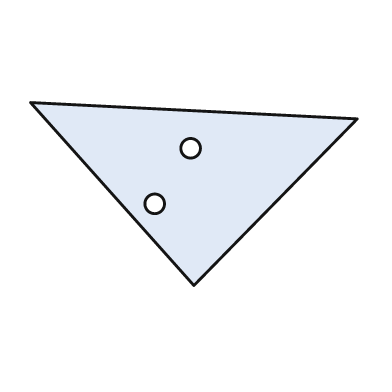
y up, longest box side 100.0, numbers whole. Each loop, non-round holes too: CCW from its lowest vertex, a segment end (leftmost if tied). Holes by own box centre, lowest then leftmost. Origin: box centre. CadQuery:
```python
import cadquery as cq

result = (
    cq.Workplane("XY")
    .moveTo(0.0, -28.0)
    .lineTo(50.0, 23.0)
    .lineTo(-50.0, 28.0)
    .close()
    .moveTo(-12.0, -3.0)
    .circle(3.0)
    .moveTo(-1.0, 14.0)
    .circle(3.0)
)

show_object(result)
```